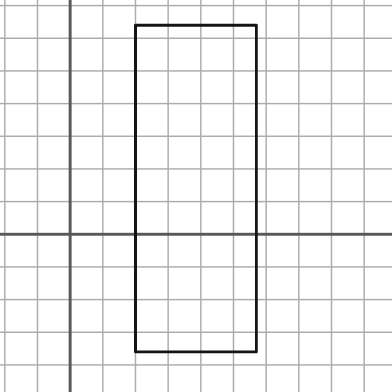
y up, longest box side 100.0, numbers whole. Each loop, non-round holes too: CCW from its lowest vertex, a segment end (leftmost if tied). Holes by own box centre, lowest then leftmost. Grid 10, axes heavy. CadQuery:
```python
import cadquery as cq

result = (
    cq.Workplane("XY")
    .moveTo(20.0, -36.0)
    .lineTo(57.0, -36.0)
    .lineTo(57.0, 64.0)
    .lineTo(20.0, 64.0)
    .close()
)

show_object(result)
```